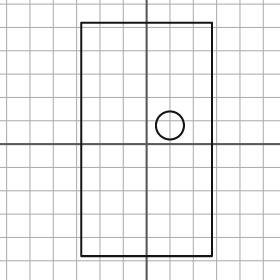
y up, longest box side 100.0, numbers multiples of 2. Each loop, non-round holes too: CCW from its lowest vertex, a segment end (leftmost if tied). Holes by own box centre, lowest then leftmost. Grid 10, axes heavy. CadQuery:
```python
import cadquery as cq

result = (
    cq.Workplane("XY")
    .moveTo(-28.0, -48.0)
    .lineTo(28.0, -48.0)
    .lineTo(28.0, 52.0)
    .lineTo(-28.0, 52.0)
    .close()
    .moveTo(10.0, 8.0)
    .circle(6.0)
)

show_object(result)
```